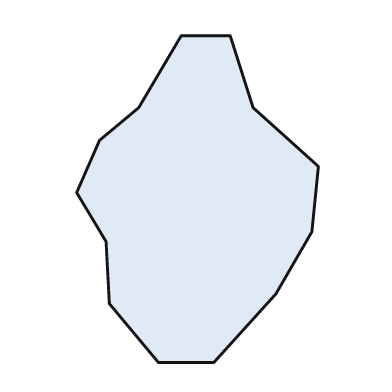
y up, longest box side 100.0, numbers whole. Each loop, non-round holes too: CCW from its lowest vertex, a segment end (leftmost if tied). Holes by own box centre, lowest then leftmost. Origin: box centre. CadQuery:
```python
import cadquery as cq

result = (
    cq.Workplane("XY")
    .moveTo(-12.0, -50.0)
    .lineTo(5.0, -50.0)
    .lineTo(24.0, -29.0)
    .lineTo(35.0, -10.0)
    .lineTo(37.0, 10.0)
    .lineTo(17.0, 28.0)
    .lineTo(10.0, 50.0)
    .lineTo(-5.0, 50.0)
    .lineTo(-18.0, 28.0)
    .lineTo(-30.0, 18.0)
    .lineTo(-37.0, 2.0)
    .lineTo(-28.0, -13.0)
    .lineTo(-27.0, -32.0)
    .close()
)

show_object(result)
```